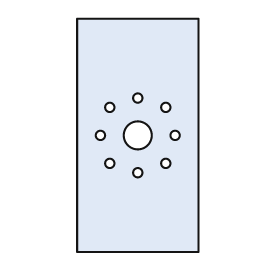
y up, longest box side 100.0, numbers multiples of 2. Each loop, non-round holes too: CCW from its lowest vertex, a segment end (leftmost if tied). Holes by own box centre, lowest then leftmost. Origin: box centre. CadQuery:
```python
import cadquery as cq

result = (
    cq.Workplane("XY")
    .moveTo(-26.0, -50.0)
    .lineTo(26.0, -50.0)
    .lineTo(26.0, 50.0)
    .lineTo(-26.0, 50.0)
    .close()
    .moveTo(0.0, -16.0)
    .circle(2.0)
    .moveTo(-12.0, -12.0)
    .circle(2.0)
    .moveTo(12.0, -12.0)
    .circle(2.0)
    .moveTo(-16.0, 0.0)
    .circle(2.0)
    .moveTo(0.0, 0.0)
    .circle(6.0)
    .moveTo(16.0, 0.0)
    .circle(2.0)
    .moveTo(-12.0, 12.0)
    .circle(2.0)
    .moveTo(12.0, 12.0)
    .circle(2.0)
    .moveTo(0.0, 16.0)
    .circle(2.0)
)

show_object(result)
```